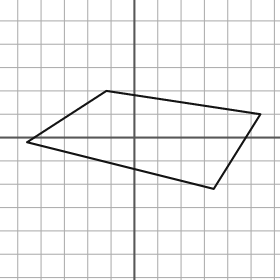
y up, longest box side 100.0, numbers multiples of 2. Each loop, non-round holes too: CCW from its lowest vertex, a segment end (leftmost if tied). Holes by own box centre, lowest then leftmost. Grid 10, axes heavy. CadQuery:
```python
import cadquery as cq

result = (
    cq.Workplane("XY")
    .moveTo(34.0, -22.0)
    .lineTo(54.0, 10.0)
    .lineTo(-12.0, 20.0)
    .lineTo(-46.0, -2.0)
    .close()
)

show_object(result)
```